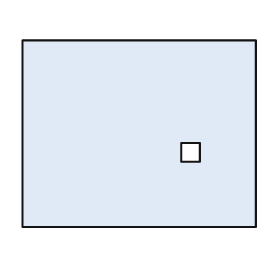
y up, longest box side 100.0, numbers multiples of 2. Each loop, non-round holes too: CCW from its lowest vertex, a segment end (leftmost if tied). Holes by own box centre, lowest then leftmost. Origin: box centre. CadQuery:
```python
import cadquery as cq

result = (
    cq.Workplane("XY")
    .moveTo(-50.0, -40.0)
    .lineTo(50.0, -40.0)
    .lineTo(50.0, 40.0)
    .lineTo(-50.0, 40.0)
    .close()
    .moveTo(18.0, -12.0)
    .lineTo(26.0, -12.0)
    .lineTo(26.0, -4.0)
    .lineTo(18.0, -4.0)
    .close()
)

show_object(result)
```